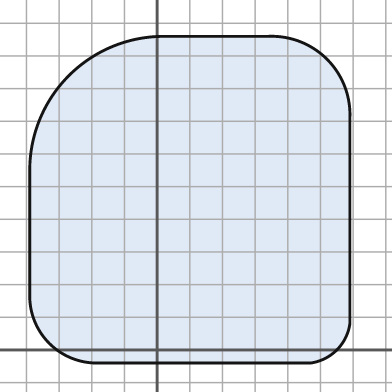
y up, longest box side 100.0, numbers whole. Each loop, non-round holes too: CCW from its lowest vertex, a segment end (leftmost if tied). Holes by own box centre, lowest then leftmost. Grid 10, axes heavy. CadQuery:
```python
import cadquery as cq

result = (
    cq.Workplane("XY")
    .moveTo(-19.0, -4.0)
    .lineTo(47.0, -4.0)
    .threePointArc((55.0, 0.0), (59.0, 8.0))
    .lineTo(59.0, 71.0)
    .threePointArc((52.0, 89.0), (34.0, 96.0))
    .lineTo(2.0, 96.0)
    .threePointArc((-27.0, 84.0), (-39.0, 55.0))
    .lineTo(-39.0, 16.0)
    .threePointArc((-33.0, 2.0), (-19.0, -4.0))
    .close()
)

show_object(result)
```